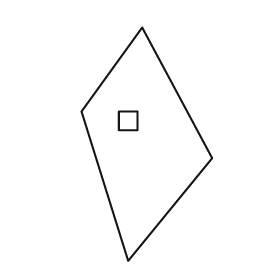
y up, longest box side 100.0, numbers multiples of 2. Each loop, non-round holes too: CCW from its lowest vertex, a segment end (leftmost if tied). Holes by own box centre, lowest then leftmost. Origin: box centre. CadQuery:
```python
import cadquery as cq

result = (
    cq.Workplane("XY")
    .moveTo(-8.0, -50.0)
    .lineTo(28.0, -6.0)
    .lineTo(-2.0, 50.0)
    .lineTo(-28.0, 14.0)
    .close()
    .moveTo(-12.0, 6.0)
    .lineTo(-4.0, 6.0)
    .lineTo(-4.0, 14.0)
    .lineTo(-12.0, 14.0)
    .close()
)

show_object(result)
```